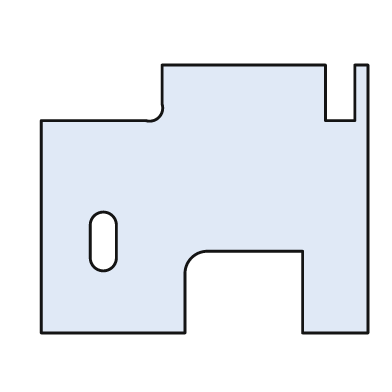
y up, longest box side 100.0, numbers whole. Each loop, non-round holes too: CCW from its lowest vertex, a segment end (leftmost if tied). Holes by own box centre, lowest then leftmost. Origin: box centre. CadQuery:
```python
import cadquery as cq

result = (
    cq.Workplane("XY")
    .moveTo(-50.0, -41.0)
    .lineTo(-6.0, -41.0)
    .lineTo(-6.0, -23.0)
    .threePointArc((-4.0, -18.0), (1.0, -16.0))
    .lineTo(30.0, -16.0)
    .lineTo(30.0, -41.0)
    .lineTo(50.0, -41.0)
    .lineTo(50.0, 41.0)
    .lineTo(46.0, 41.0)
    .lineTo(46.0, 24.0)
    .lineTo(37.0, 24.0)
    .lineTo(37.0, 41.0)
    .lineTo(-13.0, 41.0)
    .lineTo(-13.0, 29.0)
    .threePointArc((-14.0, 25.0), (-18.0, 24.0))
    .lineTo(-50.0, 24.0)
    .close()
    .moveTo(-35.0, -18.0)
    .threePointArc((-31.0, -22.0), (-27.0, -18.0))
    .lineTo(-27.0, -8.0)
    .threePointArc((-31.0, -4.0), (-35.0, -8.0))
    .close()
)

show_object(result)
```